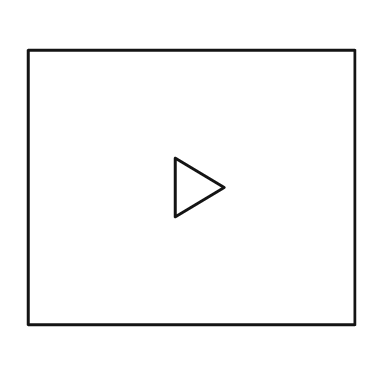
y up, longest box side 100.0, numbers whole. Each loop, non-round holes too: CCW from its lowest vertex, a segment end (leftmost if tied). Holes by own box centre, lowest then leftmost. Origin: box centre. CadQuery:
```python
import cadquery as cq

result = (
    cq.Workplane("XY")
    .moveTo(-50.0, -42.0)
    .lineTo(50.0, -42.0)
    .lineTo(50.0, 42.0)
    .lineTo(-50.0, 42.0)
    .close()
    .moveTo(-5.0, -9.0)
    .lineTo(10.0, 0.0)
    .lineTo(-5.0, 9.0)
    .close()
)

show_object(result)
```